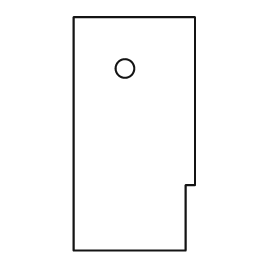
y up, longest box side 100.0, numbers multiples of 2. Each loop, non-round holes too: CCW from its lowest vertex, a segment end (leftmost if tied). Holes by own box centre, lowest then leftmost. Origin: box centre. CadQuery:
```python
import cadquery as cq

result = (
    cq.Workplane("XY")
    .moveTo(-26.0, -50.0)
    .lineTo(22.0, -50.0)
    .lineTo(22.0, -22.0)
    .lineTo(26.0, -22.0)
    .lineTo(26.0, 50.0)
    .lineTo(-26.0, 50.0)
    .close()
    .moveTo(-4.0, 28.0)
    .circle(4.0)
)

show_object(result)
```